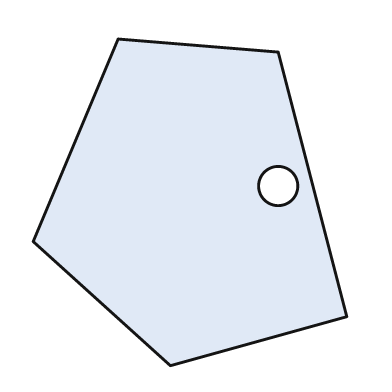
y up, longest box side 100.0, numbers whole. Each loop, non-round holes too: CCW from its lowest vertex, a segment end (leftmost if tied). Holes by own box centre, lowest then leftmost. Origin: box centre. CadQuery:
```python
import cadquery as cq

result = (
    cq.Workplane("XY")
    .moveTo(-6.0, -50.0)
    .lineTo(48.0, -35.0)
    .lineTo(27.0, 46.0)
    .lineTo(-22.0, 50.0)
    .lineTo(-48.0, -12.0)
    .close()
    .moveTo(27.0, 5.0)
    .circle(6.0)
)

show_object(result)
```